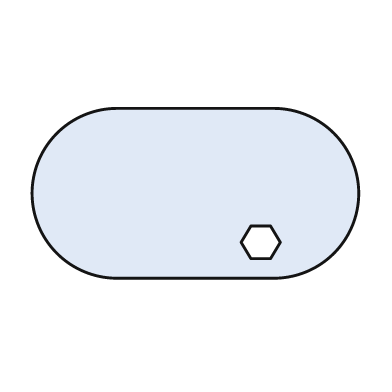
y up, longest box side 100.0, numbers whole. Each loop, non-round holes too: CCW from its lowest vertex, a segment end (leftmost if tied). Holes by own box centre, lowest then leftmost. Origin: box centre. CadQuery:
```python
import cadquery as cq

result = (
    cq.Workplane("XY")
    .moveTo(-24.0, -26.0)
    .lineTo(24.0, -26.0)
    .threePointArc((50.0, 0.0), (24.0, 26.0))
    .lineTo(-24.0, 26.0)
    .threePointArc((-50.0, 0.0), (-24.0, -26.0))
    .close()
    .moveTo(17.0, -20.0)
    .lineTo(23.0, -20.0)
    .lineTo(26.0, -15.0)
    .lineTo(23.0, -10.0)
    .lineTo(17.0, -10.0)
    .lineTo(14.0, -15.0)
    .close()
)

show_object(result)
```